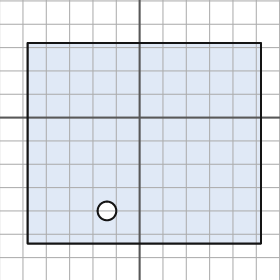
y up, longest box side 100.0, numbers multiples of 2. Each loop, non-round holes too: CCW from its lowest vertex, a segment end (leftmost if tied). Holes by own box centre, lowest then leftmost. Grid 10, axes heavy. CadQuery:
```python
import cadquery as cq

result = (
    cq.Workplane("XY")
    .moveTo(-48.0, -54.0)
    .lineTo(52.0, -54.0)
    .lineTo(52.0, 32.0)
    .lineTo(-48.0, 32.0)
    .close()
    .moveTo(-14.0, -40.0)
    .circle(4.0)
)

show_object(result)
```